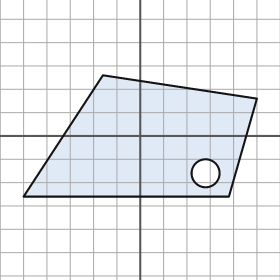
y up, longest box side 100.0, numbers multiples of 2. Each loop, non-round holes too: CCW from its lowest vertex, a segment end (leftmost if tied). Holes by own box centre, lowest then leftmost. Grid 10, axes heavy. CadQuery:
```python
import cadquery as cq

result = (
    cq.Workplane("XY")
    .moveTo(-50.0, -26.0)
    .lineTo(38.0, -26.0)
    .lineTo(50.0, 16.0)
    .lineTo(-16.0, 26.0)
    .close()
    .moveTo(28.0, -16.0)
    .circle(6.0)
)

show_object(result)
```